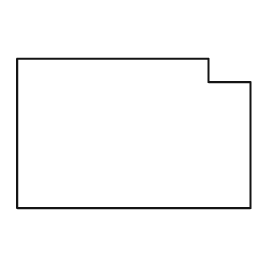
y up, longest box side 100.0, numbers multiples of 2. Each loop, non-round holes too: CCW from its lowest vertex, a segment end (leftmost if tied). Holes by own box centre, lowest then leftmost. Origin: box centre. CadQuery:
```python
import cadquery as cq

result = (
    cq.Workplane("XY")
    .moveTo(-50.0, -32.0)
    .lineTo(50.0, -32.0)
    .lineTo(50.0, 22.0)
    .lineTo(32.0, 22.0)
    .lineTo(32.0, 32.0)
    .lineTo(-50.0, 32.0)
    .close()
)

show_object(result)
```